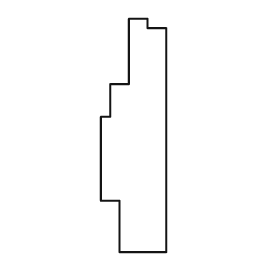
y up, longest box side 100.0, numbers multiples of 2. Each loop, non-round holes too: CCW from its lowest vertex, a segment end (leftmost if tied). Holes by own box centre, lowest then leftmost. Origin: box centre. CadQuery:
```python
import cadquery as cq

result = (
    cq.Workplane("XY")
    .moveTo(-6.0, -50.0)
    .lineTo(14.0, -50.0)
    .lineTo(14.0, 46.0)
    .lineTo(6.0, 46.0)
    .lineTo(6.0, 50.0)
    .lineTo(-2.0, 50.0)
    .lineTo(-2.0, 22.0)
    .lineTo(-10.0, 22.0)
    .lineTo(-10.0, 8.0)
    .lineTo(-14.0, 8.0)
    .lineTo(-14.0, -28.0)
    .lineTo(-6.0, -28.0)
    .close()
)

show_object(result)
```